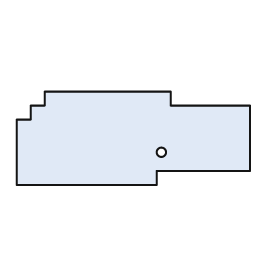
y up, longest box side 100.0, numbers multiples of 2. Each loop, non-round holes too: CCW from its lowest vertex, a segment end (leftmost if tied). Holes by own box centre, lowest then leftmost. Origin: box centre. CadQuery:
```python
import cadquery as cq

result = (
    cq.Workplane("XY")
    .moveTo(-50.0, -20.0)
    .lineTo(10.0, -20.0)
    .lineTo(10.0, -14.0)
    .lineTo(50.0, -14.0)
    .lineTo(50.0, 14.0)
    .lineTo(16.0, 14.0)
    .lineTo(16.0, 20.0)
    .lineTo(-38.0, 20.0)
    .lineTo(-38.0, 14.0)
    .lineTo(-44.0, 14.0)
    .lineTo(-44.0, 8.0)
    .lineTo(-50.0, 8.0)
    .close()
    .moveTo(12.0, -6.0)
    .circle(2.0)
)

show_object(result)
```